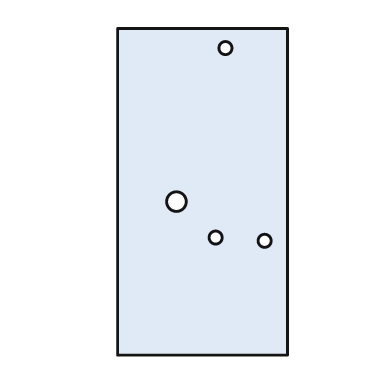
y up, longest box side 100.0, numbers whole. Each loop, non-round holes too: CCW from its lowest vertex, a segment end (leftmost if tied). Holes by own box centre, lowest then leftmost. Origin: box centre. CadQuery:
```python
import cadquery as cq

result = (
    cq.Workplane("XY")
    .moveTo(-26.0, -50.0)
    .lineTo(26.0, -50.0)
    .lineTo(26.0, 50.0)
    .lineTo(-26.0, 50.0)
    .close()
    .moveTo(19.0, -15.0)
    .circle(2.0)
    .moveTo(4.0, -14.0)
    .circle(2.0)
    .moveTo(-8.0, -3.0)
    .circle(3.0)
    .moveTo(7.0, 44.0)
    .circle(2.0)
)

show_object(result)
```